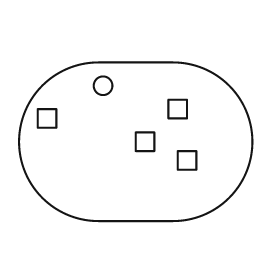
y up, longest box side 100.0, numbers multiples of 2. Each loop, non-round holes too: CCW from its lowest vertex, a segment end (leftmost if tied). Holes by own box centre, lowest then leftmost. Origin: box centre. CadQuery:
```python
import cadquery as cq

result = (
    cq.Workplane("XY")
    .moveTo(-16.0, -34.0)
    .lineTo(16.0, -34.0)
    .threePointArc((50.0, 0.0), (16.0, 34.0))
    .lineTo(-16.0, 34.0)
    .threePointArc((-50.0, 0.0), (-16.0, -34.0))
    .close()
    .moveTo(18.0, -12.0)
    .lineTo(26.0, -12.0)
    .lineTo(26.0, -4.0)
    .lineTo(18.0, -4.0)
    .close()
    .moveTo(0.0, -4.0)
    .lineTo(8.0, -4.0)
    .lineTo(8.0, 4.0)
    .lineTo(0.0, 4.0)
    .close()
    .moveTo(-42.0, 6.0)
    .lineTo(-34.0, 6.0)
    .lineTo(-34.0, 14.0)
    .lineTo(-42.0, 14.0)
    .close()
    .moveTo(14.0, 10.0)
    .lineTo(22.0, 10.0)
    .lineTo(22.0, 18.0)
    .lineTo(14.0, 18.0)
    .close()
    .moveTo(-14.0, 24.0)
    .circle(4.0)
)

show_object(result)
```